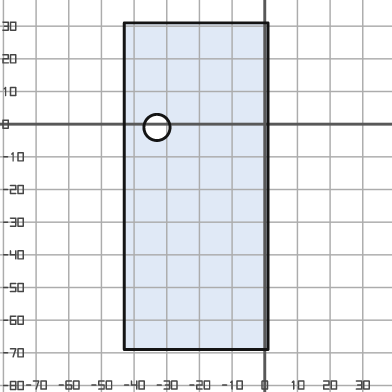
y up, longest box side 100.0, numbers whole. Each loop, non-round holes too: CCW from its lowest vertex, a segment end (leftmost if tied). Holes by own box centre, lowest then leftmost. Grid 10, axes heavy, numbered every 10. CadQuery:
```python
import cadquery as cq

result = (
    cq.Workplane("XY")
    .moveTo(-43.0, -69.0)
    .lineTo(1.0, -69.0)
    .lineTo(1.0, 31.0)
    .lineTo(-43.0, 31.0)
    .close()
    .moveTo(-33.0, -1.0)
    .circle(4.0)
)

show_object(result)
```